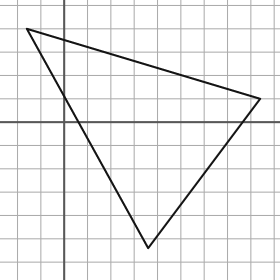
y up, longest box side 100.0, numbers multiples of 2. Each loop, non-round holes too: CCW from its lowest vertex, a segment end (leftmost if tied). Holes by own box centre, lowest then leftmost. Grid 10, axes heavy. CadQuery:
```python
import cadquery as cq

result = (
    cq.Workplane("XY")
    .moveTo(36.0, -54.0)
    .lineTo(84.0, 10.0)
    .lineTo(-16.0, 40.0)
    .close()
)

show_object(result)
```